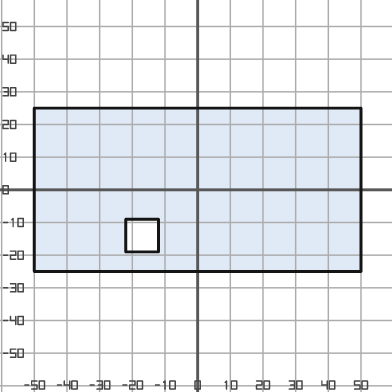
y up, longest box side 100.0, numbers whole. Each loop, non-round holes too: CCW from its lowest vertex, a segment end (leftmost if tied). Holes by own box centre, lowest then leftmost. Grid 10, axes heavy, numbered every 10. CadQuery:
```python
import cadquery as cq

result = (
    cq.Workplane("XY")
    .moveTo(-50.0, -25.0)
    .lineTo(50.0, -25.0)
    .lineTo(50.0, 25.0)
    .lineTo(-50.0, 25.0)
    .close()
    .moveTo(-22.0, -19.0)
    .lineTo(-12.0, -19.0)
    .lineTo(-12.0, -9.0)
    .lineTo(-22.0, -9.0)
    .close()
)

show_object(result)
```